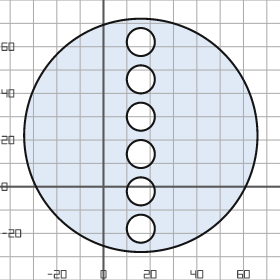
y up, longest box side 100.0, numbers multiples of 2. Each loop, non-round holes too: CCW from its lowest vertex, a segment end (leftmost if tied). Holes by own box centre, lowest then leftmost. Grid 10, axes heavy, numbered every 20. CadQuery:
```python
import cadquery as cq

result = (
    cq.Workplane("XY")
    .moveTo(16.0, 22.0)
    .circle(50.0)
    .moveTo(16.0, -18.0)
    .circle(6.0)
    .moveTo(16.0, -2.0)
    .circle(6.0)
    .moveTo(16.0, 14.0)
    .circle(6.0)
    .moveTo(16.0, 30.0)
    .circle(6.0)
    .moveTo(16.0, 46.0)
    .circle(6.0)
    .moveTo(16.0, 62.0)
    .circle(6.0)
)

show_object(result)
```